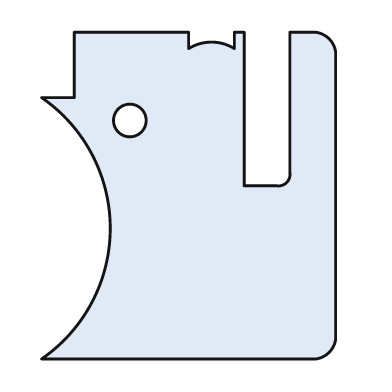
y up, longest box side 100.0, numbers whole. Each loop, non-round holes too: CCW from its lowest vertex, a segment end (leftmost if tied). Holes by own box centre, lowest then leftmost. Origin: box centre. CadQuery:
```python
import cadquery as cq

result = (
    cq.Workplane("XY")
    .moveTo(-45.0, -50.0)
    .lineTo(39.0, -50.0)
    .threePointArc((43.0, -48.0), (45.0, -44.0))
    .lineTo(45.0, 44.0)
    .threePointArc((43.0, 48.0), (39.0, 50.0))
    .lineTo(31.0, 50.0)
    .lineTo(31.0, 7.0)
    .threePointArc((30.0, 4.0), (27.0, 3.0))
    .lineTo(17.0, 3.0)
    .lineTo(17.0, 50.0)
    .lineTo(14.0, 50.0)
    .lineTo(14.0, 45.0)
    .threePointArc((7.0, 47.0), (0.0, 45.0))
    .lineTo(0.0, 50.0)
    .lineTo(-35.0, 50.0)
    .lineTo(-35.0, 30.0)
    .lineTo(-45.0, 30.0)
    .threePointArc((-24.0, -10.0), (-45.0, -50.0))
    .close()
    .moveTo(-18.0, 23.0)
    .circle(5.0)
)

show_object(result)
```